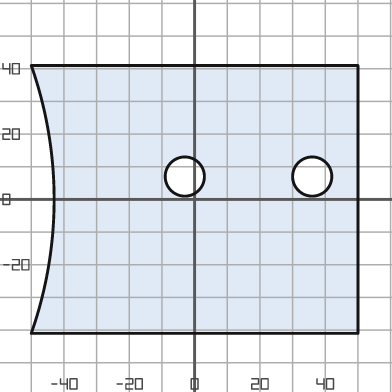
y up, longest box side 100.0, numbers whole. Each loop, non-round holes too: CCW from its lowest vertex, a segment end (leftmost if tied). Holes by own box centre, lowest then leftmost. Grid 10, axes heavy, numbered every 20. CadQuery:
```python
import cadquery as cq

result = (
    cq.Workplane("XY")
    .moveTo(-50.0, -41.0)
    .lineTo(50.0, -41.0)
    .lineTo(50.0, 41.0)
    .lineTo(-50.0, 41.0)
    .threePointArc((-43.0, 0.0), (-50.0, -41.0))
    .close()
    .moveTo(-3.0, 7.0)
    .circle(6.0)
    .moveTo(36.0, 7.0)
    .circle(6.0)
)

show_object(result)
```